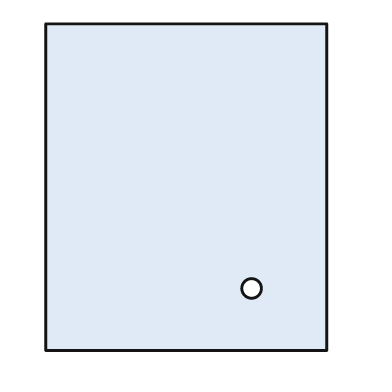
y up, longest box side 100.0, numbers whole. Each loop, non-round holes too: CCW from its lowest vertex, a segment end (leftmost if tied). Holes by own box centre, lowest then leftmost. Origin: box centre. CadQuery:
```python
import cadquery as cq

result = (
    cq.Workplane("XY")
    .moveTo(-43.0, -50.0)
    .lineTo(43.0, -50.0)
    .lineTo(43.0, 50.0)
    .lineTo(-43.0, 50.0)
    .close()
    .moveTo(20.0, -31.0)
    .circle(3.0)
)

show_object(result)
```